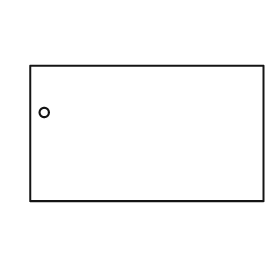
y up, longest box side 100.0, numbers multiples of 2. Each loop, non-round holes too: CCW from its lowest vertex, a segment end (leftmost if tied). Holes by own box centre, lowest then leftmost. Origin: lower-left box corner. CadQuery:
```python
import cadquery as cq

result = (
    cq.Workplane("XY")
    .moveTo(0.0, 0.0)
    .lineTo(100.0, 0.0)
    .lineTo(100.0, 58.0)
    .lineTo(0.0, 58.0)
    .close()
    .moveTo(6.0, 38.0)
    .circle(2.0)
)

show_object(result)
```